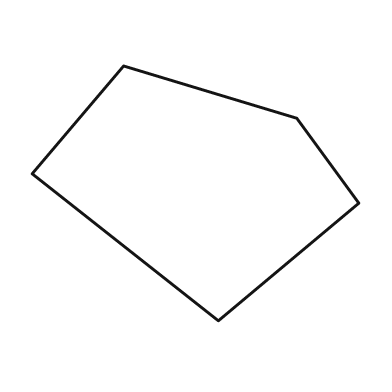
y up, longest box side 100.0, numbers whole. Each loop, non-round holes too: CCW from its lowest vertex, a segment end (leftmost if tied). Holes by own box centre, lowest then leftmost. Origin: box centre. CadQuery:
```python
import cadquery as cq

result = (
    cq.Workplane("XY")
    .moveTo(7.0, -39.0)
    .lineTo(50.0, -3.0)
    .lineTo(31.0, 23.0)
    .lineTo(-22.0, 39.0)
    .lineTo(-50.0, 6.0)
    .close()
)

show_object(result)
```